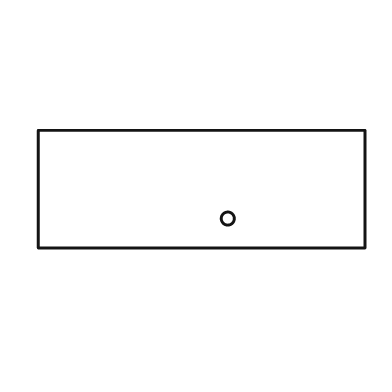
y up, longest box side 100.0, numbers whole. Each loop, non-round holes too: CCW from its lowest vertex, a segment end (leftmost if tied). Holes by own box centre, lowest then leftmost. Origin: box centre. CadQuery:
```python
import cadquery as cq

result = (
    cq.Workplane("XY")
    .moveTo(-50.0, -18.0)
    .lineTo(50.0, -18.0)
    .lineTo(50.0, 18.0)
    .lineTo(-50.0, 18.0)
    .close()
    .moveTo(8.0, -9.0)
    .circle(2.0)
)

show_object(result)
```